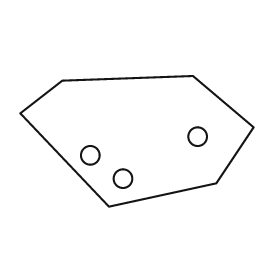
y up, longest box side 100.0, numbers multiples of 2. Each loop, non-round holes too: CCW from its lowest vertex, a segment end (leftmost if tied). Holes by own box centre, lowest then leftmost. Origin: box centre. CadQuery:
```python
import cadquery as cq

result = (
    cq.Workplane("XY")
    .moveTo(-12.0, -28.0)
    .lineTo(34.0, -18.0)
    .lineTo(50.0, 6.0)
    .lineTo(24.0, 28.0)
    .lineTo(-32.0, 26.0)
    .lineTo(-50.0, 12.0)
    .close()
    .moveTo(-6.0, -16.0)
    .circle(4.0)
    .moveTo(-20.0, -6.0)
    .circle(4.0)
    .moveTo(26.0, 2.0)
    .circle(4.0)
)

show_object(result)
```